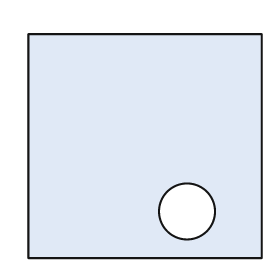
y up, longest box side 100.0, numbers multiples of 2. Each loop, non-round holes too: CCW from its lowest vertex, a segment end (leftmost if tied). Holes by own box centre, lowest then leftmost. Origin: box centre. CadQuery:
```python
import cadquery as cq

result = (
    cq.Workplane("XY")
    .moveTo(-50.0, -48.0)
    .lineTo(50.0, -48.0)
    .lineTo(50.0, 48.0)
    .lineTo(-50.0, 48.0)
    .close()
    .moveTo(18.0, -28.0)
    .circle(12.0)
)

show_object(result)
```